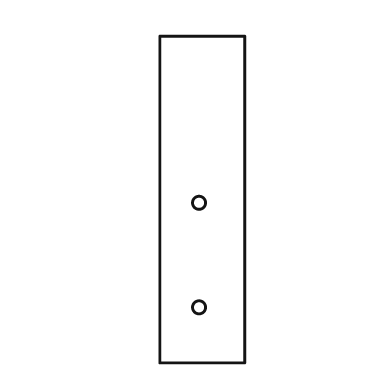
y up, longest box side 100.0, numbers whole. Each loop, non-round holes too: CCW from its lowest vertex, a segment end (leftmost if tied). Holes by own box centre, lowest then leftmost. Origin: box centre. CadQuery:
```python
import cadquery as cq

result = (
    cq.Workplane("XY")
    .moveTo(-13.0, -50.0)
    .lineTo(13.0, -50.0)
    .lineTo(13.0, 50.0)
    .lineTo(-13.0, 50.0)
    .close()
    .moveTo(-1.0, -33.0)
    .circle(2.0)
    .moveTo(-1.0, -1.0)
    .circle(2.0)
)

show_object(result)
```